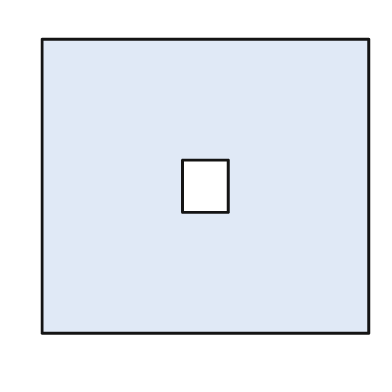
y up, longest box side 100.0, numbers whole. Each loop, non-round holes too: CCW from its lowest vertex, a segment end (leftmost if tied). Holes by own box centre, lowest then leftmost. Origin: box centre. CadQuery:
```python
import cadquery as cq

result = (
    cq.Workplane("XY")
    .moveTo(-50.0, -45.0)
    .lineTo(50.0, -45.0)
    .lineTo(50.0, 45.0)
    .lineTo(-50.0, 45.0)
    .close()
    .moveTo(-7.0, -8.0)
    .lineTo(7.0, -8.0)
    .lineTo(7.0, 8.0)
    .lineTo(-7.0, 8.0)
    .close()
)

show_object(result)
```